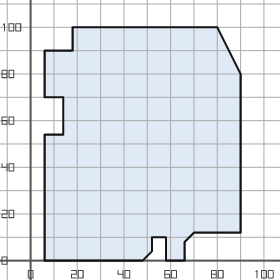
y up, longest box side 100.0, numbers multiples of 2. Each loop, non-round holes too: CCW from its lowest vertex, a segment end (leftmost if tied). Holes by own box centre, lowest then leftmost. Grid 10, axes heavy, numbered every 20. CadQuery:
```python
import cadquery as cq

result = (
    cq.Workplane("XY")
    .moveTo(6.0, 0.0)
    .lineTo(48.0, 0.0)
    .lineTo(52.0, 4.0)
    .lineTo(52.0, 10.0)
    .lineTo(58.0, 10.0)
    .lineTo(58.0, 0.0)
    .lineTo(66.0, 0.0)
    .lineTo(66.0, 8.0)
    .lineTo(70.0, 12.0)
    .lineTo(90.0, 12.0)
    .lineTo(90.0, 80.0)
    .lineTo(80.0, 100.0)
    .lineTo(18.0, 100.0)
    .lineTo(18.0, 90.0)
    .lineTo(6.0, 90.0)
    .lineTo(6.0, 70.0)
    .lineTo(14.0, 70.0)
    .lineTo(14.0, 54.0)
    .lineTo(6.0, 54.0)
    .close()
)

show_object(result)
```